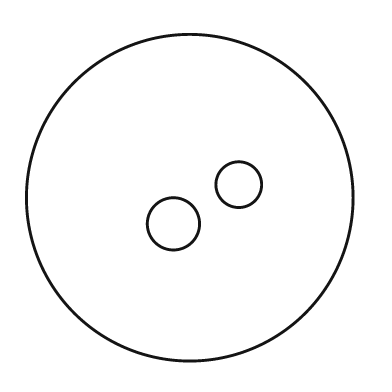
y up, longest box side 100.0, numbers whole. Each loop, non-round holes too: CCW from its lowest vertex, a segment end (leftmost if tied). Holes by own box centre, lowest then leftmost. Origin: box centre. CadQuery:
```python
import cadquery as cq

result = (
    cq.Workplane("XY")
    .moveTo(0.0, 0.0)
    .circle(50.0)
    .moveTo(-5.0, -8.0)
    .circle(8.0)
    .moveTo(15.0, 4.0)
    .circle(7.0)
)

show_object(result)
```